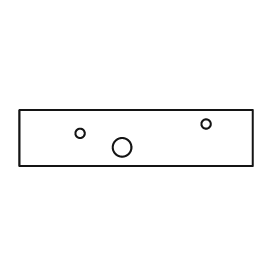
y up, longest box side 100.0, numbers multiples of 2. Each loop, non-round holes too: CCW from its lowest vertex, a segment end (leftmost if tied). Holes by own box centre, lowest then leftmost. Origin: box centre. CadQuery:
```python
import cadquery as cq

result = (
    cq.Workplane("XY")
    .moveTo(-50.0, -12.0)
    .lineTo(50.0, -12.0)
    .lineTo(50.0, 12.0)
    .lineTo(-50.0, 12.0)
    .close()
    .moveTo(-6.0, -4.0)
    .circle(4.0)
    .moveTo(-24.0, 2.0)
    .circle(2.0)
    .moveTo(30.0, 6.0)
    .circle(2.0)
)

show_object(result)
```